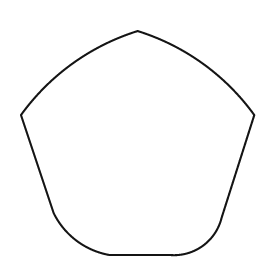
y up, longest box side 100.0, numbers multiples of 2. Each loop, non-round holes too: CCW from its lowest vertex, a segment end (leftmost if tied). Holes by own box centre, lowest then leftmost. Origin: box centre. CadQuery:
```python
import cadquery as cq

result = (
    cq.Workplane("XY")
    .moveTo(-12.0, -48.0)
    .lineTo(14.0, -48.0)
    .threePointArc((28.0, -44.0), (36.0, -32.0))
    .lineTo(50.0, 12.0)
    .threePointArc((28.0, 34.0), (0.0, 48.0))
    .threePointArc((-28.0, 34.0), (-50.0, 12.0))
    .lineTo(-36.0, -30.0)
    .threePointArc((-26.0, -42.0), (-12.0, -48.0))
    .close()
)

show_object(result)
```